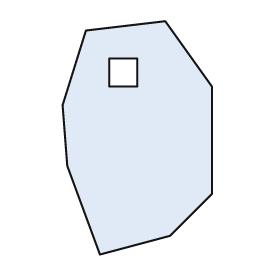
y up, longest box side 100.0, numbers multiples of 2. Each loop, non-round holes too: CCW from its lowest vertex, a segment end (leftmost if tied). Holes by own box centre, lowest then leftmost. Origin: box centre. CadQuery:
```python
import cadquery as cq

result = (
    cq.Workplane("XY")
    .moveTo(-16.0, -50.0)
    .lineTo(14.0, -42.0)
    .lineTo(32.0, -24.0)
    .lineTo(32.0, 22.0)
    .lineTo(12.0, 50.0)
    .lineTo(-22.0, 46.0)
    .lineTo(-32.0, 14.0)
    .lineTo(-30.0, -12.0)
    .close()
    .moveTo(-12.0, 22.0)
    .lineTo(0.0, 22.0)
    .lineTo(0.0, 34.0)
    .lineTo(-12.0, 34.0)
    .close()
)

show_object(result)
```